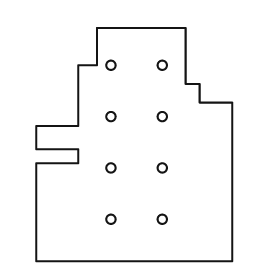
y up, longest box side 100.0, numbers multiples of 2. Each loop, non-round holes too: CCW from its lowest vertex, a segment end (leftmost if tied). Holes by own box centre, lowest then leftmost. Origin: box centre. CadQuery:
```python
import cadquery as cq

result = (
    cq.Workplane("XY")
    .moveTo(-42.0, -50.0)
    .lineTo(42.0, -50.0)
    .lineTo(42.0, 18.0)
    .lineTo(28.0, 18.0)
    .lineTo(28.0, 26.0)
    .lineTo(22.0, 26.0)
    .lineTo(22.0, 50.0)
    .lineTo(-16.0, 50.0)
    .lineTo(-16.0, 34.0)
    .lineTo(-24.0, 34.0)
    .lineTo(-24.0, 8.0)
    .lineTo(-42.0, 8.0)
    .lineTo(-42.0, -2.0)
    .lineTo(-24.0, -2.0)
    .lineTo(-24.0, -8.0)
    .lineTo(-42.0, -8.0)
    .close()
    .moveTo(-10.0, -32.0)
    .circle(2.0)
    .moveTo(12.0, -32.0)
    .circle(2.0)
    .moveTo(-10.0, -10.0)
    .circle(2.0)
    .moveTo(12.0, -10.0)
    .circle(2.0)
    .moveTo(-10.0, 12.0)
    .circle(2.0)
    .moveTo(12.0, 12.0)
    .circle(2.0)
    .moveTo(-10.0, 34.0)
    .circle(2.0)
    .moveTo(12.0, 34.0)
    .circle(2.0)
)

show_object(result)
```